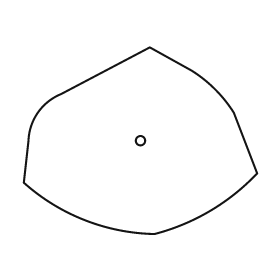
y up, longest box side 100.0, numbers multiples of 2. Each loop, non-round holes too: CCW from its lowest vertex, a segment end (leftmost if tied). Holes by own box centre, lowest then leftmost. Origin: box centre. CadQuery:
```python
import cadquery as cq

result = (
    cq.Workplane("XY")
    .moveTo(6.0, -40.0)
    .threePointArc((30.0, -30.0), (50.0, -14.0))
    .lineTo(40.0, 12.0)
    .threePointArc((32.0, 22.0), (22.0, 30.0))
    .lineTo(4.0, 40.0)
    .lineTo(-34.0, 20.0)
    .threePointArc((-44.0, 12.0), (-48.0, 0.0))
    .lineTo(-50.0, -18.0)
    .threePointArc((-24.0, -34.0), (6.0, -40.0))
    .close()
    .moveTo(0.0, 0.0)
    .circle(2.0)
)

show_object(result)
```